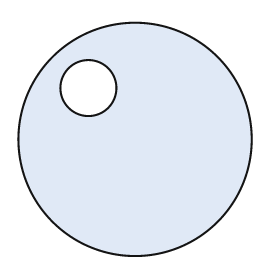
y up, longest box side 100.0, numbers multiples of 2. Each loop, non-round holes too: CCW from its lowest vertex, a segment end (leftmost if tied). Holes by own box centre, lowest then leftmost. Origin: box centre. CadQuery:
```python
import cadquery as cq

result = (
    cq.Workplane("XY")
    .moveTo(0.0, 0.0)
    .circle(50.0)
    .moveTo(-20.0, 22.0)
    .circle(12.0)
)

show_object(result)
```